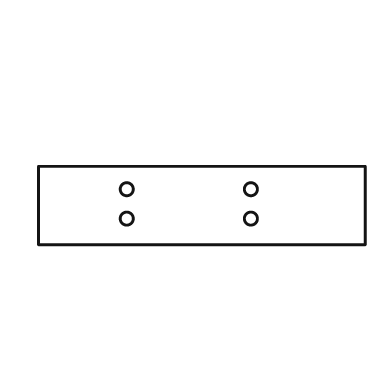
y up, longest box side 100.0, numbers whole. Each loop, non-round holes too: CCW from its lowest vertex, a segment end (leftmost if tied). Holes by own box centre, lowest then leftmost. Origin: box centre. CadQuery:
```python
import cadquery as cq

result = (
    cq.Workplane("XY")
    .moveTo(-50.0, -12.0)
    .lineTo(50.0, -12.0)
    .lineTo(50.0, 12.0)
    .lineTo(-50.0, 12.0)
    .close()
    .moveTo(-23.0, -4.0)
    .circle(2.0)
    .moveTo(15.0, -4.0)
    .circle(2.0)
    .moveTo(-23.0, 5.0)
    .circle(2.0)
    .moveTo(15.0, 5.0)
    .circle(2.0)
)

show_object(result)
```